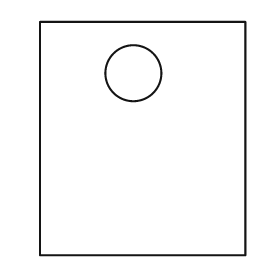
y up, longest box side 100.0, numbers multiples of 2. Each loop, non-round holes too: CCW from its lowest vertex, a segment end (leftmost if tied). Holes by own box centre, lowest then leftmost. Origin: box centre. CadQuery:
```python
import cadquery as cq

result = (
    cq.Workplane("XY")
    .moveTo(-44.0, -50.0)
    .lineTo(44.0, -50.0)
    .lineTo(44.0, 50.0)
    .lineTo(-44.0, 50.0)
    .close()
    .moveTo(-4.0, 28.0)
    .circle(12.0)
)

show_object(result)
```